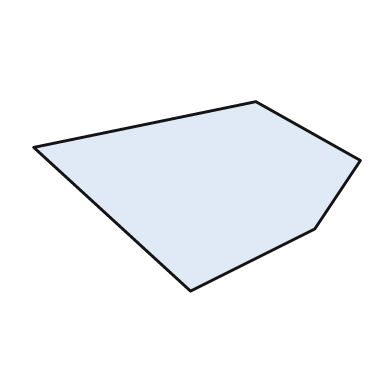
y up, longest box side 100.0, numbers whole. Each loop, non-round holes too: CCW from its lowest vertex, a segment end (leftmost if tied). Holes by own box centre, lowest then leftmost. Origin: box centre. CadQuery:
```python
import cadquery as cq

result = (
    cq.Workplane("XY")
    .moveTo(-2.0, -29.0)
    .lineTo(36.0, -10.0)
    .lineTo(50.0, 11.0)
    .lineTo(18.0, 29.0)
    .lineTo(-50.0, 15.0)
    .close()
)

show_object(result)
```